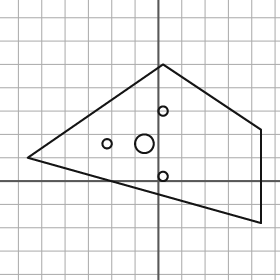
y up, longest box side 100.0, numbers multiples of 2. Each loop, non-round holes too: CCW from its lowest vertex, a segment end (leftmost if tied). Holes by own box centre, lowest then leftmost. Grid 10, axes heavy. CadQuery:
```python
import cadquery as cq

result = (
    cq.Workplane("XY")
    .moveTo(44.0, -18.0)
    .lineTo(44.0, 22.0)
    .lineTo(2.0, 50.0)
    .lineTo(-56.0, 10.0)
    .close()
    .moveTo(2.0, 2.0)
    .circle(2.0)
    .moveTo(-22.0, 16.0)
    .circle(2.0)
    .moveTo(-6.0, 16.0)
    .circle(4.0)
    .moveTo(2.0, 30.0)
    .circle(2.0)
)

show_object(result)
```